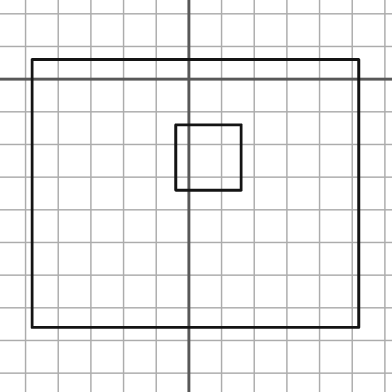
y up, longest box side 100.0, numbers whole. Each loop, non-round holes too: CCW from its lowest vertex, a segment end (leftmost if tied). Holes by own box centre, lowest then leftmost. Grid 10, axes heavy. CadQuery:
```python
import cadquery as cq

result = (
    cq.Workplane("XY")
    .moveTo(-48.0, -76.0)
    .lineTo(52.0, -76.0)
    .lineTo(52.0, 6.0)
    .lineTo(-48.0, 6.0)
    .close()
    .moveTo(-4.0, -34.0)
    .lineTo(16.0, -34.0)
    .lineTo(16.0, -14.0)
    .lineTo(-4.0, -14.0)
    .close()
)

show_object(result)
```